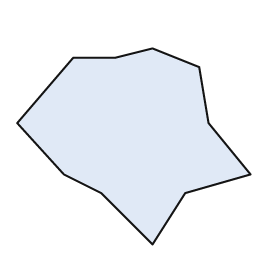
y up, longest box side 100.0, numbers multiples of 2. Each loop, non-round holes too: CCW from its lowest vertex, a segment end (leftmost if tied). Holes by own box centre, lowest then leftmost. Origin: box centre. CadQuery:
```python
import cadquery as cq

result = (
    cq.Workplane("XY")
    .moveTo(8.0, -42.0)
    .lineTo(22.0, -20.0)
    .lineTo(50.0, -12.0)
    .lineTo(32.0, 10.0)
    .lineTo(28.0, 34.0)
    .lineTo(8.0, 42.0)
    .lineTo(-8.0, 38.0)
    .lineTo(-26.0, 38.0)
    .lineTo(-50.0, 10.0)
    .lineTo(-30.0, -12.0)
    .lineTo(-14.0, -20.0)
    .close()
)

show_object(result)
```